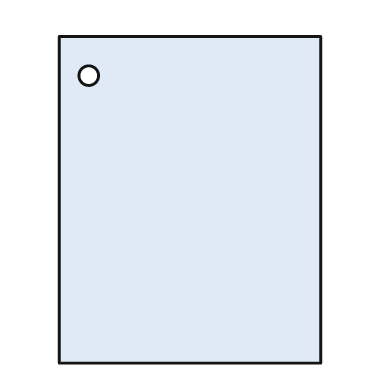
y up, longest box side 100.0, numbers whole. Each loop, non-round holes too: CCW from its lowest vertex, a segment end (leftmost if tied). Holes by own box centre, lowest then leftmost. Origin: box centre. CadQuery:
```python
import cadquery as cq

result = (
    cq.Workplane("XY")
    .moveTo(-40.0, -50.0)
    .lineTo(40.0, -50.0)
    .lineTo(40.0, 50.0)
    .lineTo(-40.0, 50.0)
    .close()
    .moveTo(-31.0, 38.0)
    .circle(3.0)
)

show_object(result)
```